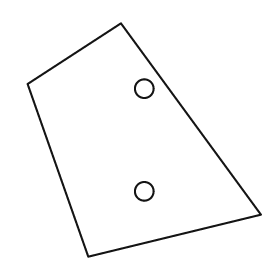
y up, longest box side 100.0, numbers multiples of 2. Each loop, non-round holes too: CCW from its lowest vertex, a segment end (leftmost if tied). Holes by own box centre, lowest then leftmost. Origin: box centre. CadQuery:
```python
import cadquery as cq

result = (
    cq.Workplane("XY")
    .moveTo(-24.0, -50.0)
    .lineTo(50.0, -32.0)
    .lineTo(-10.0, 50.0)
    .lineTo(-50.0, 24.0)
    .close()
    .moveTo(0.0, -22.0)
    .circle(4.0)
    .moveTo(0.0, 22.0)
    .circle(4.0)
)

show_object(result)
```